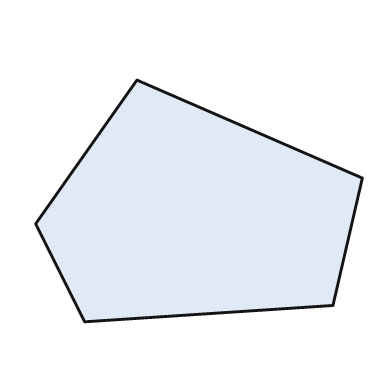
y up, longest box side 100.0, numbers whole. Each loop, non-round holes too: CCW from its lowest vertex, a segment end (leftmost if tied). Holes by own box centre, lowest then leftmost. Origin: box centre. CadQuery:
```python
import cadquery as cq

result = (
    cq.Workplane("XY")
    .moveTo(-35.0, -37.0)
    .lineTo(41.0, -32.0)
    .lineTo(50.0, 7.0)
    .lineTo(-19.0, 37.0)
    .lineTo(-50.0, -7.0)
    .close()
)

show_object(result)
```